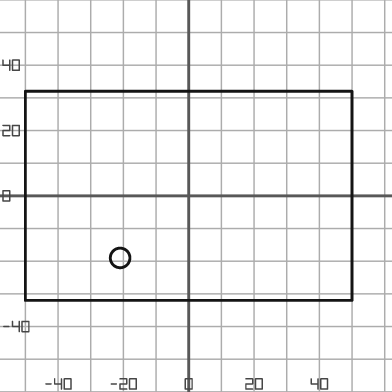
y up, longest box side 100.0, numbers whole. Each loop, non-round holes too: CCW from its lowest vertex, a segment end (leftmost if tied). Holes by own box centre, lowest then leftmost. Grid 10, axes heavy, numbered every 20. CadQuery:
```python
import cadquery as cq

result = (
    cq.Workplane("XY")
    .moveTo(-50.0, -32.0)
    .lineTo(50.0, -32.0)
    .lineTo(50.0, 32.0)
    .lineTo(-50.0, 32.0)
    .close()
    .moveTo(-21.0, -19.0)
    .circle(3.0)
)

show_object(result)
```